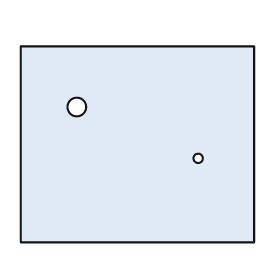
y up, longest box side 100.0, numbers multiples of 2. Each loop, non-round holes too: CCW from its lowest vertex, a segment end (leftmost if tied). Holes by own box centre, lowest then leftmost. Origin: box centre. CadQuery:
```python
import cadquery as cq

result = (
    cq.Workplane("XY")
    .moveTo(-50.0, -42.0)
    .lineTo(50.0, -42.0)
    .lineTo(50.0, 42.0)
    .lineTo(-50.0, 42.0)
    .close()
    .moveTo(26.0, -6.0)
    .circle(2.0)
    .moveTo(-26.0, 16.0)
    .circle(4.0)
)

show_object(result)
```